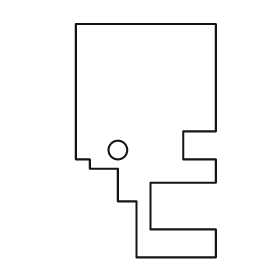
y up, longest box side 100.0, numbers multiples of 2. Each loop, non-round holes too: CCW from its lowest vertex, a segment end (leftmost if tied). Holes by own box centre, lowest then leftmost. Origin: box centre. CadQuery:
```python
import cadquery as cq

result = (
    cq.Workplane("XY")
    .moveTo(-4.0, -50.0)
    .lineTo(30.0, -50.0)
    .lineTo(30.0, -38.0)
    .lineTo(2.0, -38.0)
    .lineTo(2.0, -18.0)
    .lineTo(30.0, -18.0)
    .lineTo(30.0, -8.0)
    .lineTo(16.0, -8.0)
    .lineTo(16.0, 4.0)
    .lineTo(30.0, 4.0)
    .lineTo(30.0, 50.0)
    .lineTo(-30.0, 50.0)
    .lineTo(-30.0, -8.0)
    .lineTo(-24.0, -8.0)
    .lineTo(-24.0, -12.0)
    .lineTo(-12.0, -12.0)
    .lineTo(-12.0, -26.0)
    .lineTo(-4.0, -26.0)
    .close()
    .moveTo(-12.0, -4.0)
    .circle(4.0)
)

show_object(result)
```